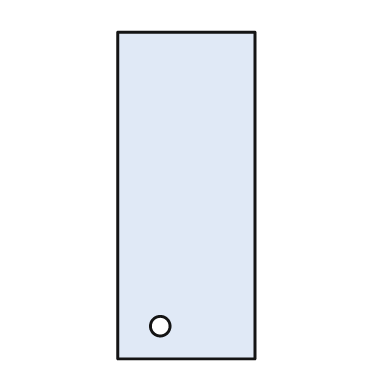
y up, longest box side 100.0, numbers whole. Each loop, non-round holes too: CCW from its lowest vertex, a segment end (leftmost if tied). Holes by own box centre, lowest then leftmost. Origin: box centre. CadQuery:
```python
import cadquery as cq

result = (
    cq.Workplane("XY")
    .moveTo(-21.0, -50.0)
    .lineTo(21.0, -50.0)
    .lineTo(21.0, 50.0)
    .lineTo(-21.0, 50.0)
    .close()
    .moveTo(-8.0, -40.0)
    .circle(3.0)
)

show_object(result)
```